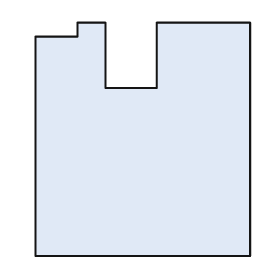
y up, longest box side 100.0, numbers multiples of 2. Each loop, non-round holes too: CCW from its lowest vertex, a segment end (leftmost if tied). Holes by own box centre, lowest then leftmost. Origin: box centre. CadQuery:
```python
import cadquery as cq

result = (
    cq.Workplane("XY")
    .moveTo(-46.0, -50.0)
    .lineTo(46.0, -50.0)
    .lineTo(46.0, 50.0)
    .lineTo(6.0, 50.0)
    .lineTo(6.0, 22.0)
    .lineTo(-16.0, 22.0)
    .lineTo(-16.0, 50.0)
    .lineTo(-28.0, 50.0)
    .lineTo(-28.0, 44.0)
    .lineTo(-46.0, 44.0)
    .close()
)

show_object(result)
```